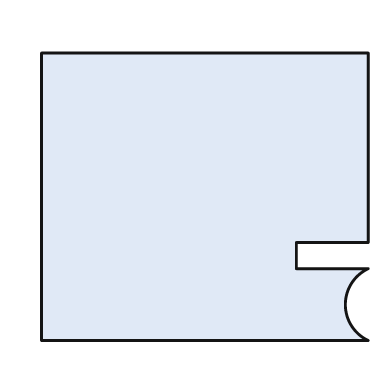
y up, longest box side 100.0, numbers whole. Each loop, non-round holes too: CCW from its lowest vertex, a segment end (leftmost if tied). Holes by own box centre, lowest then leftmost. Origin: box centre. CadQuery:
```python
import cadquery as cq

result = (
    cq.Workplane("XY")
    .moveTo(-50.0, -44.0)
    .lineTo(50.0, -44.0)
    .threePointArc((43.0, -33.0), (50.0, -22.0))
    .lineTo(28.0, -22.0)
    .lineTo(28.0, -14.0)
    .lineTo(50.0, -14.0)
    .lineTo(50.0, 44.0)
    .lineTo(-50.0, 44.0)
    .close()
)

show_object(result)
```